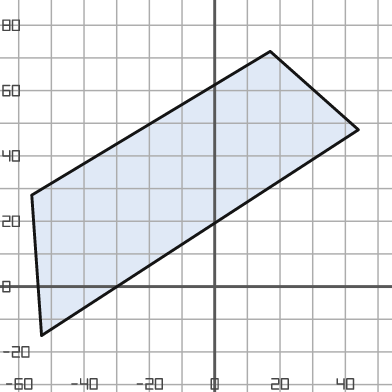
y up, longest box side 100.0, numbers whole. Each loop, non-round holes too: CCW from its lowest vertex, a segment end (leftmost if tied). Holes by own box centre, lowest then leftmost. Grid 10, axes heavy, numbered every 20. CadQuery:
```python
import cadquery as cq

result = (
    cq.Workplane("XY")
    .moveTo(-53.0, -15.0)
    .lineTo(44.0, 48.0)
    .lineTo(17.0, 72.0)
    .lineTo(-56.0, 28.0)
    .close()
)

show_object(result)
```